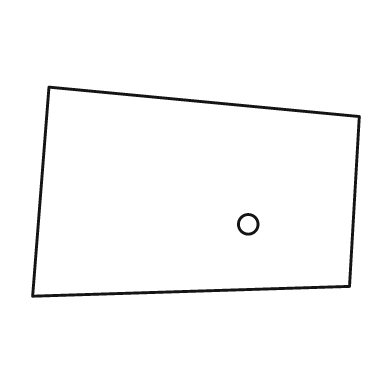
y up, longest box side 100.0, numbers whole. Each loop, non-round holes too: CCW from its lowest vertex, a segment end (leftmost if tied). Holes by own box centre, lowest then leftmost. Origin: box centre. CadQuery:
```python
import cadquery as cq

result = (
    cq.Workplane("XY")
    .moveTo(-50.0, -32.0)
    .lineTo(47.0, -29.0)
    .lineTo(50.0, 23.0)
    .lineTo(-45.0, 32.0)
    .close()
    .moveTo(16.0, -10.0)
    .circle(3.0)
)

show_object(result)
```